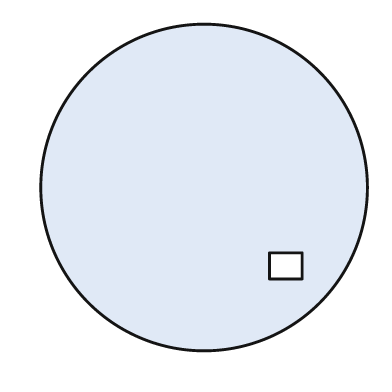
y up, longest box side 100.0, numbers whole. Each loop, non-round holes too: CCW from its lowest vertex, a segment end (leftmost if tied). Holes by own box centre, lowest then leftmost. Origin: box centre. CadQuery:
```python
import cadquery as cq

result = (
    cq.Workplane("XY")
    .moveTo(0.0, 0.0)
    .circle(50.0)
    .moveTo(20.0, -28.0)
    .lineTo(30.0, -28.0)
    .lineTo(30.0, -20.0)
    .lineTo(20.0, -20.0)
    .close()
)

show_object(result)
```